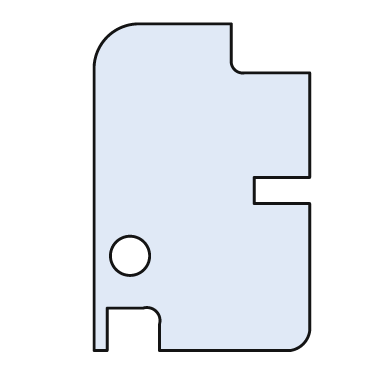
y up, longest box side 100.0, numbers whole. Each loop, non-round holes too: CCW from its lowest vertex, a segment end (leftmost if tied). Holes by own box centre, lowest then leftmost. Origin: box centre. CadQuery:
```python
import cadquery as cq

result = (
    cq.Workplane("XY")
    .moveTo(-33.0, -50.0)
    .lineTo(-29.0, -50.0)
    .lineTo(-29.0, -37.0)
    .lineTo(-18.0, -37.0)
    .threePointArc((-14.0, -38.0), (-13.0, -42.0))
    .lineTo(-13.0, -50.0)
    .lineTo(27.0, -50.0)
    .threePointArc((31.0, -48.0), (33.0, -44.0))
    .lineTo(33.0, -5.0)
    .lineTo(16.0, -5.0)
    .lineTo(16.0, 3.0)
    .lineTo(33.0, 3.0)
    .lineTo(33.0, 35.0)
    .lineTo(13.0, 35.0)
    .threePointArc((10.0, 36.0), (9.0, 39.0))
    .lineTo(9.0, 50.0)
    .lineTo(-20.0, 50.0)
    .threePointArc((-29.0, 46.0), (-33.0, 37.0))
    .close()
    .moveTo(-22.0, -21.0)
    .circle(6.0)
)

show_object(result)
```